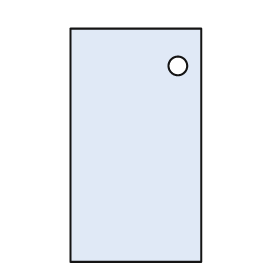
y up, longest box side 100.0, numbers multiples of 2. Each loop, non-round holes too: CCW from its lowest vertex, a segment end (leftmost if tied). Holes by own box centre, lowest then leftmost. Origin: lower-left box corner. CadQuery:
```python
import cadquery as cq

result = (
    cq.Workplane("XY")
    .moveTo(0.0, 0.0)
    .lineTo(56.0, 0.0)
    .lineTo(56.0, 100.0)
    .lineTo(0.0, 100.0)
    .close()
    .moveTo(46.0, 84.0)
    .circle(4.0)
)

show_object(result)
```